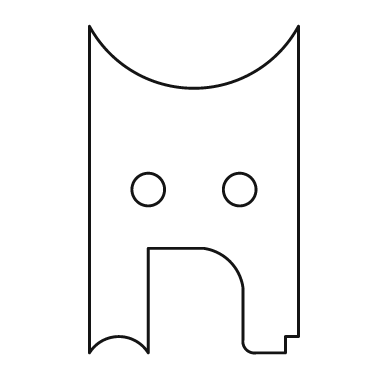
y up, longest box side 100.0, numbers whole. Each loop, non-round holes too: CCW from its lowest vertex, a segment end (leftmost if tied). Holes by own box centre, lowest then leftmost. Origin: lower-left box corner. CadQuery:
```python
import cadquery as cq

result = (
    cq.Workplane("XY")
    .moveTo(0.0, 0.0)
    .threePointArc((9.0, 5.0), (18.0, 0.0))
    .lineTo(18.0, 32.0)
    .lineTo(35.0, 32.0)
    .threePointArc((43.0, 28.0), (47.0, 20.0))
    .lineTo(47.0, 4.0)
    .threePointArc((48.0, 1.0), (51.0, 0.0))
    .lineTo(60.0, 0.0)
    .lineTo(60.0, 5.0)
    .lineTo(64.0, 5.0)
    .lineTo(64.0, 100.0)
    .threePointArc((32.0, 81.0), (0.0, 100.0))
    .close()
    .moveTo(18.0, 50.0)
    .circle(5.0)
    .moveTo(46.0, 50.0)
    .circle(5.0)
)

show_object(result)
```